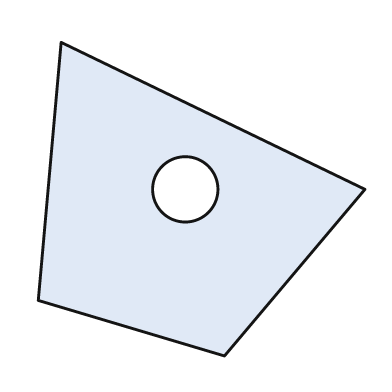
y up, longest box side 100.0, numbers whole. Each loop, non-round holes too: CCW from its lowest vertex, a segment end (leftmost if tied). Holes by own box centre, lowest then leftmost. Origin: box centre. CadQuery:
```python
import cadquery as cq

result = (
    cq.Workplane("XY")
    .moveTo(7.0, -48.0)
    .lineTo(50.0, 3.0)
    .lineTo(-43.0, 48.0)
    .lineTo(-50.0, -31.0)
    .close()
    .moveTo(-5.0, 3.0)
    .circle(10.0)
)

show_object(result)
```